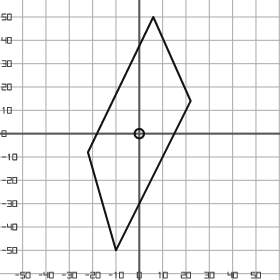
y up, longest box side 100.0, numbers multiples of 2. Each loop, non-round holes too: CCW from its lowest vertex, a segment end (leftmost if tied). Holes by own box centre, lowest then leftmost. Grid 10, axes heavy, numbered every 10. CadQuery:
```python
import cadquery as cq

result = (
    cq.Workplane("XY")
    .moveTo(-10.0, -50.0)
    .lineTo(22.0, 14.0)
    .lineTo(6.0, 50.0)
    .lineTo(-22.0, -8.0)
    .close()
    .moveTo(0.0, 0.0)
    .circle(2.0)
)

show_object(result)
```